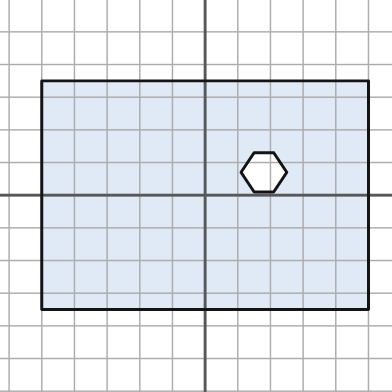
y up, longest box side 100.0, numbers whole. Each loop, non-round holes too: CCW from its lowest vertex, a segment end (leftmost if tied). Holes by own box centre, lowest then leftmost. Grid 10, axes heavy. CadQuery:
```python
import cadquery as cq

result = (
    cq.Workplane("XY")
    .moveTo(-50.0, -35.0)
    .lineTo(50.0, -35.0)
    .lineTo(50.0, 35.0)
    .lineTo(-50.0, 35.0)
    .close()
    .moveTo(15.0, 1.0)
    .lineTo(21.0, 1.0)
    .lineTo(25.0, 7.0)
    .lineTo(21.0, 13.0)
    .lineTo(15.0, 13.0)
    .lineTo(11.0, 7.0)
    .close()
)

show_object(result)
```